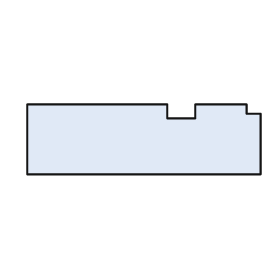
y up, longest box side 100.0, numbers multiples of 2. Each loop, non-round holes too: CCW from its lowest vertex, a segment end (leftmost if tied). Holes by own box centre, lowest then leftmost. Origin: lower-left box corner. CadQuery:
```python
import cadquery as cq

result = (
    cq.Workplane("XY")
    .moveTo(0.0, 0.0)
    .lineTo(100.0, 0.0)
    .lineTo(100.0, 26.0)
    .lineTo(94.0, 26.0)
    .lineTo(94.0, 30.0)
    .lineTo(72.0, 30.0)
    .lineTo(72.0, 24.0)
    .lineTo(60.0, 24.0)
    .lineTo(60.0, 30.0)
    .lineTo(0.0, 30.0)
    .close()
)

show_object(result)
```